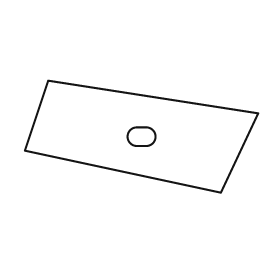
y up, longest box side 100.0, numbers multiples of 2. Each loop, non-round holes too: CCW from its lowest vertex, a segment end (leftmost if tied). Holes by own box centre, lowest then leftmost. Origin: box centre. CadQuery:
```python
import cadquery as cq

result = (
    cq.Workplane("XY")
    .moveTo(34.0, -24.0)
    .lineTo(50.0, 10.0)
    .lineTo(-40.0, 24.0)
    .lineTo(-50.0, -6.0)
    .close()
    .moveTo(-2.0, -4.0)
    .lineTo(2.0, -4.0)
    .threePointArc((6.0, 0.0), (2.0, 4.0))
    .lineTo(-2.0, 4.0)
    .threePointArc((-6.0, 0.0), (-2.0, -4.0))
    .close()
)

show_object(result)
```